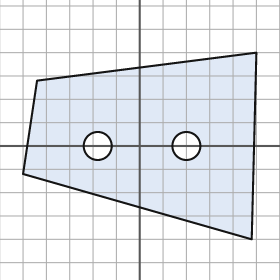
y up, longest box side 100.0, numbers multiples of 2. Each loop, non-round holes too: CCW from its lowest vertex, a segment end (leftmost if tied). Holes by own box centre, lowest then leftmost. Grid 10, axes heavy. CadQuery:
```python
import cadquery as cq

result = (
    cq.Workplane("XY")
    .moveTo(48.0, -40.0)
    .lineTo(50.0, 40.0)
    .lineTo(-44.0, 28.0)
    .lineTo(-50.0, -12.0)
    .close()
    .moveTo(-18.0, 0.0)
    .circle(6.0)
    .moveTo(20.0, 0.0)
    .circle(6.0)
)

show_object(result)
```